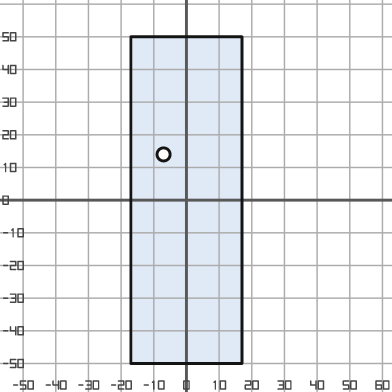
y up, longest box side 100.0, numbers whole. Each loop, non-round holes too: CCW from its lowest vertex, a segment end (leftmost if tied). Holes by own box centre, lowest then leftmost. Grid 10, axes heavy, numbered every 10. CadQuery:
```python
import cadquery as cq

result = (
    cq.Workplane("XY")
    .moveTo(-17.0, -50.0)
    .lineTo(17.0, -50.0)
    .lineTo(17.0, 50.0)
    .lineTo(-17.0, 50.0)
    .close()
    .moveTo(-7.0, 14.0)
    .circle(2.0)
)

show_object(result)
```